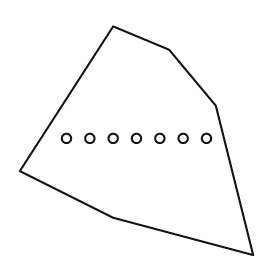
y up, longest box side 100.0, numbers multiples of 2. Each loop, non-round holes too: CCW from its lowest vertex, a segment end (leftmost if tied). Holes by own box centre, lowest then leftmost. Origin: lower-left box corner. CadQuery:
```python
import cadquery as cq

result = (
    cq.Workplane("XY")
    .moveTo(100.0, 0.0)
    .lineTo(84.0, 64.0)
    .lineTo(64.0, 88.0)
    .lineTo(40.0, 98.0)
    .lineTo(0.0, 36.0)
    .lineTo(40.0, 16.0)
    .close()
    .moveTo(20.0, 50.0)
    .circle(2.0)
    .moveTo(30.0, 50.0)
    .circle(2.0)
    .moveTo(40.0, 50.0)
    .circle(2.0)
    .moveTo(50.0, 50.0)
    .circle(2.0)
    .moveTo(60.0, 50.0)
    .circle(2.0)
    .moveTo(70.0, 50.0)
    .circle(2.0)
    .moveTo(80.0, 50.0)
    .circle(2.0)
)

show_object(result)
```